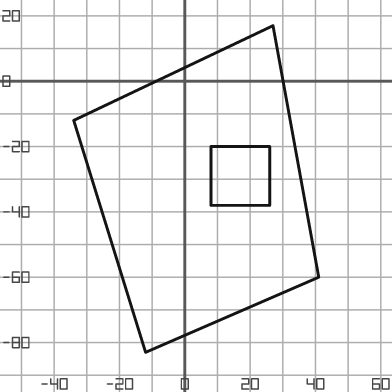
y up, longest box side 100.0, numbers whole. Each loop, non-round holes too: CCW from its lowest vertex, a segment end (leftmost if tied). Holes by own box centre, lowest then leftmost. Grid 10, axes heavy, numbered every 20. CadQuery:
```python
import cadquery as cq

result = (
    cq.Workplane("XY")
    .moveTo(-12.0, -83.0)
    .lineTo(41.0, -60.0)
    .lineTo(27.0, 17.0)
    .lineTo(-34.0, -12.0)
    .close()
    .moveTo(8.0, -38.0)
    .lineTo(26.0, -38.0)
    .lineTo(26.0, -20.0)
    .lineTo(8.0, -20.0)
    .close()
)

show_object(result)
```